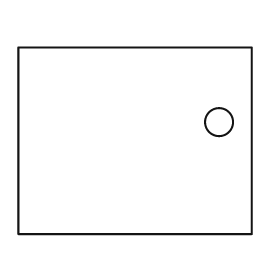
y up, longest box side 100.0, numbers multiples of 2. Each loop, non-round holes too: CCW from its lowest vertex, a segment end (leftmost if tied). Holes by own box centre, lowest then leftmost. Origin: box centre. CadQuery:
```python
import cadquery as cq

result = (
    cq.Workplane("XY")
    .moveTo(-50.0, -40.0)
    .lineTo(50.0, -40.0)
    .lineTo(50.0, 40.0)
    .lineTo(-50.0, 40.0)
    .close()
    .moveTo(36.0, 8.0)
    .circle(6.0)
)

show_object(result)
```